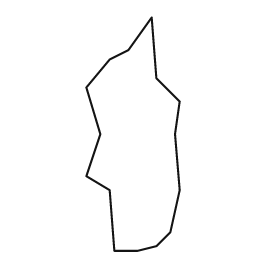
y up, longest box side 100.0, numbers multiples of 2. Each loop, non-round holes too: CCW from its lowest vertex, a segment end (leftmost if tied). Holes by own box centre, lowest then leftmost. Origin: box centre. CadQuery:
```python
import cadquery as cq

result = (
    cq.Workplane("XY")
    .moveTo(-8.0, -50.0)
    .lineTo(2.0, -50.0)
    .lineTo(10.0, -48.0)
    .lineTo(16.0, -42.0)
    .lineTo(20.0, -24.0)
    .lineTo(18.0, 0.0)
    .lineTo(20.0, 14.0)
    .lineTo(10.0, 24.0)
    .lineTo(8.0, 50.0)
    .lineTo(-2.0, 36.0)
    .lineTo(-10.0, 32.0)
    .lineTo(-20.0, 20.0)
    .lineTo(-14.0, 0.0)
    .lineTo(-20.0, -18.0)
    .lineTo(-10.0, -24.0)
    .close()
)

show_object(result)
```